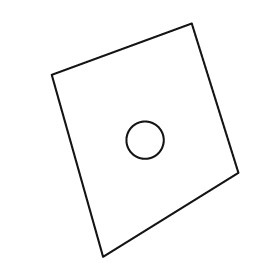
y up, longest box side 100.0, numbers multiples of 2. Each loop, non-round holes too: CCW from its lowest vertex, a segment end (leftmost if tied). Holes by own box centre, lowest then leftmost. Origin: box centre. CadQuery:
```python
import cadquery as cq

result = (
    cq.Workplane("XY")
    .moveTo(-18.0, -50.0)
    .lineTo(40.0, -14.0)
    .lineTo(20.0, 50.0)
    .lineTo(-40.0, 28.0)
    .close()
    .moveTo(0.0, 0.0)
    .circle(8.0)
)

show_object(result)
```